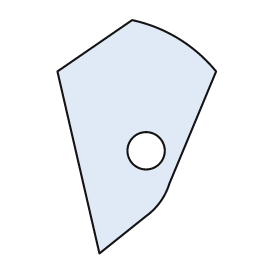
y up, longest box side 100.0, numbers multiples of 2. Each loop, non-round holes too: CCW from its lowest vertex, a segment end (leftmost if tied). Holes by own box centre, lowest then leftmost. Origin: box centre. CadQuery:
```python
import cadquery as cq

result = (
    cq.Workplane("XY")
    .moveTo(-16.0, -50.0)
    .lineTo(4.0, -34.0)
    .threePointArc((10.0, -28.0), (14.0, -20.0))
    .lineTo(34.0, 28.0)
    .threePointArc((18.0, 42.0), (-2.0, 50.0))
    .lineTo(-34.0, 28.0)
    .close()
    .moveTo(4.0, -6.0)
    .circle(8.0)
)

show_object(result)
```